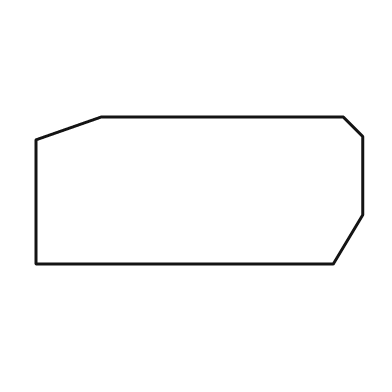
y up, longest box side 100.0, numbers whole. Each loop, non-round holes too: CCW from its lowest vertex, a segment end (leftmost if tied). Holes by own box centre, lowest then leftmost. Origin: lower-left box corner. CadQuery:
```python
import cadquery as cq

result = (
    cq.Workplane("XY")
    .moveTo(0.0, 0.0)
    .lineTo(91.0, 0.0)
    .lineTo(100.0, 15.0)
    .lineTo(100.0, 39.0)
    .lineTo(94.0, 45.0)
    .lineTo(20.0, 45.0)
    .lineTo(0.0, 38.0)
    .close()
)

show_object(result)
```